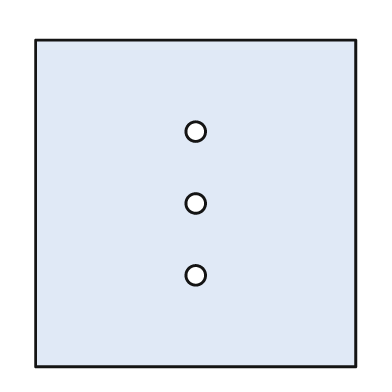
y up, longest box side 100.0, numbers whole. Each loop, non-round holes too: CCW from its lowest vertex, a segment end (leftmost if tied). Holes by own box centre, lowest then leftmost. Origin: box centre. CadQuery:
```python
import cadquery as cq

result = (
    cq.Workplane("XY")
    .moveTo(-49.0, -50.0)
    .lineTo(49.0, -50.0)
    .lineTo(49.0, 50.0)
    .lineTo(-49.0, 50.0)
    .close()
    .moveTo(0.0, -22.0)
    .circle(3.0)
    .moveTo(0.0, 0.0)
    .circle(3.0)
    .moveTo(0.0, 22.0)
    .circle(3.0)
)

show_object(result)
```